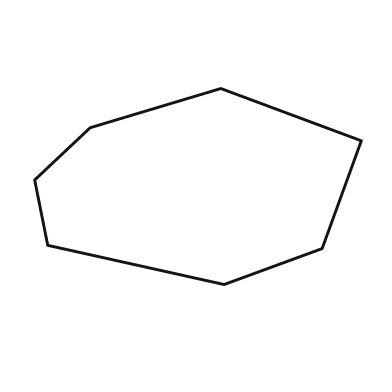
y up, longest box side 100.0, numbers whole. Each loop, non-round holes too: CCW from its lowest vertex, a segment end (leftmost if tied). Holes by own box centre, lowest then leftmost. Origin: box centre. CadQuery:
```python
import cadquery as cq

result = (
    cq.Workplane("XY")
    .moveTo(8.0, -30.0)
    .lineTo(38.0, -19.0)
    .lineTo(50.0, 14.0)
    .lineTo(7.0, 30.0)
    .lineTo(-33.0, 18.0)
    .lineTo(-50.0, 2.0)
    .lineTo(-46.0, -18.0)
    .close()
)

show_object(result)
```